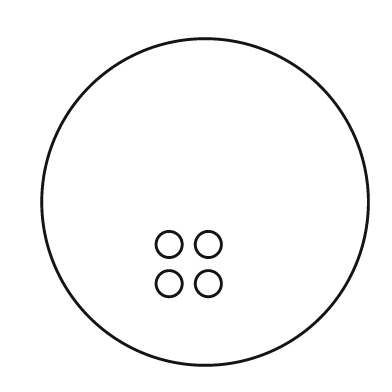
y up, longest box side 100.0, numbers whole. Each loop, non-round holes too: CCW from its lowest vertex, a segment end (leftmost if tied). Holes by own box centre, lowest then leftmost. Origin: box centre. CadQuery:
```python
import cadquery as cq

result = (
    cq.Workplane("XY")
    .moveTo(0.0, 0.0)
    .circle(50.0)
    .moveTo(-11.0, -25.0)
    .circle(4.0)
    .moveTo(1.0, -25.0)
    .circle(4.0)
    .moveTo(-11.0, -13.0)
    .circle(4.0)
    .moveTo(1.0, -13.0)
    .circle(4.0)
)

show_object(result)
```